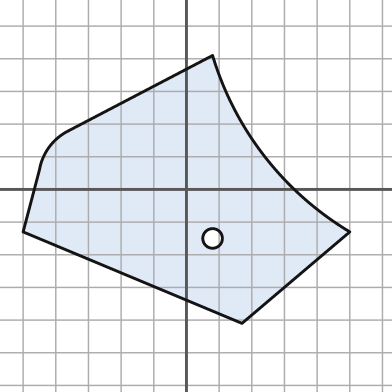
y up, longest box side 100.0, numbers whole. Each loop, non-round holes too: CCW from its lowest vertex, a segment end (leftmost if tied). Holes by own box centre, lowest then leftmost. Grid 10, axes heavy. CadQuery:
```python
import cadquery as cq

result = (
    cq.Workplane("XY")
    .moveTo(17.0, -41.0)
    .lineTo(50.0, -13.0)
    .threePointArc((24.0, 10.0), (8.0, 41.0))
    .lineTo(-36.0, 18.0)
    .threePointArc((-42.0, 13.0), (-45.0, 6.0))
    .lineTo(-50.0, -13.0)
    .close()
    .moveTo(8.0, -15.0)
    .circle(3.0)
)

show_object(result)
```